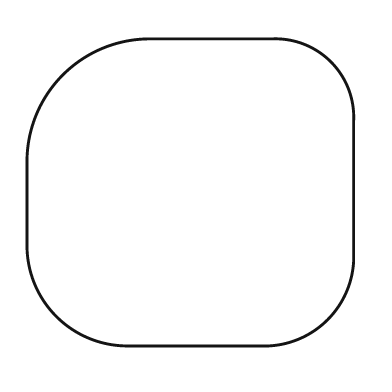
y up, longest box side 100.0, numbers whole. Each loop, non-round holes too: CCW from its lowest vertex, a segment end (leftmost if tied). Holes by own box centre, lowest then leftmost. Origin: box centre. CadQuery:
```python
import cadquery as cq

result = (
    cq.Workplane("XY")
    .moveTo(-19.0, -47.0)
    .lineTo(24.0, -47.0)
    .threePointArc((42.0, -39.0), (50.0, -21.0))
    .lineTo(50.0, 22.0)
    .threePointArc((43.0, 40.0), (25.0, 47.0))
    .lineTo(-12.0, 47.0)
    .threePointArc((-39.0, 36.0), (-50.0, 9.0))
    .lineTo(-50.0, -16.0)
    .threePointArc((-41.0, -38.0), (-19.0, -47.0))
    .close()
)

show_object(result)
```